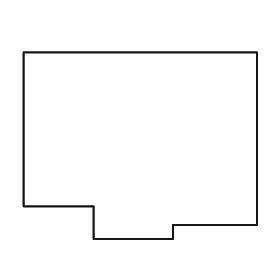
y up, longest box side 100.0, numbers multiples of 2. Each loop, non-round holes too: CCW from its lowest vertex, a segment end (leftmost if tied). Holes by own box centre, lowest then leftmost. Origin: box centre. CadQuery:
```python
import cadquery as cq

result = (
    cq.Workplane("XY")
    .moveTo(-20.0, -40.0)
    .lineTo(14.0, -40.0)
    .lineTo(14.0, -34.0)
    .lineTo(50.0, -34.0)
    .lineTo(50.0, 40.0)
    .lineTo(-50.0, 40.0)
    .lineTo(-50.0, -26.0)
    .lineTo(-20.0, -26.0)
    .close()
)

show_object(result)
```